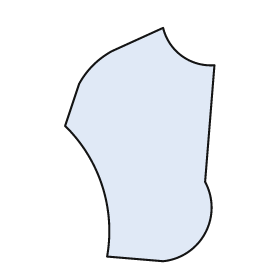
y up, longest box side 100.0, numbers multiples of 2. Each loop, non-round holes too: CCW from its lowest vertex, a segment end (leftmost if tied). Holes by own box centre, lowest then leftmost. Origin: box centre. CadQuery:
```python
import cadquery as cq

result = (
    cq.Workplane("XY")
    .moveTo(10.0, -50.0)
    .threePointArc((28.0, -38.0), (28.0, -16.0))
    .lineTo(32.0, 34.0)
    .threePointArc((18.0, 38.0), (10.0, 50.0))
    .lineTo(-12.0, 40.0)
    .threePointArc((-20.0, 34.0), (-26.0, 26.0))
    .lineTo(-32.0, 8.0)
    .threePointArc((-16.0, -18.0), (-14.0, -48.0))
    .close()
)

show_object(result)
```